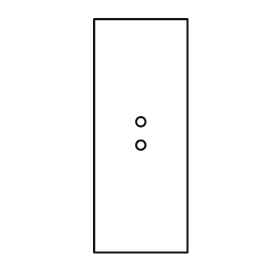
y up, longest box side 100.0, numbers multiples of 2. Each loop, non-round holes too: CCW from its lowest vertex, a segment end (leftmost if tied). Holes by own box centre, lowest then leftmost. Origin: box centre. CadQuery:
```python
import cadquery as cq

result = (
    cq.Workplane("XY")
    .moveTo(-20.0, -50.0)
    .lineTo(20.0, -50.0)
    .lineTo(20.0, 50.0)
    .lineTo(-20.0, 50.0)
    .close()
    .moveTo(0.0, -4.0)
    .circle(2.0)
    .moveTo(0.0, 6.0)
    .circle(2.0)
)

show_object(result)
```